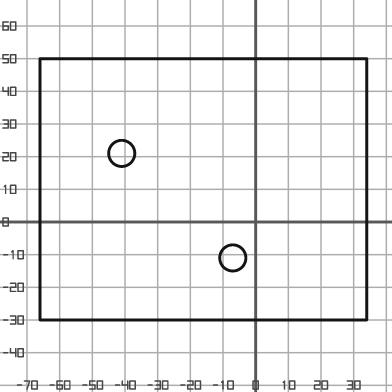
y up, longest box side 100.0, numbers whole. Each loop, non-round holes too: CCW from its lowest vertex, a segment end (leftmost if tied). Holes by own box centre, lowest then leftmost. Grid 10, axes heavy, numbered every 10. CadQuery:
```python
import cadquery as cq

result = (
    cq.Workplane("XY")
    .moveTo(-66.0, -30.0)
    .lineTo(34.0, -30.0)
    .lineTo(34.0, 50.0)
    .lineTo(-66.0, 50.0)
    .close()
    .moveTo(-7.0, -11.0)
    .circle(4.0)
    .moveTo(-41.0, 21.0)
    .circle(4.0)
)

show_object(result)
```